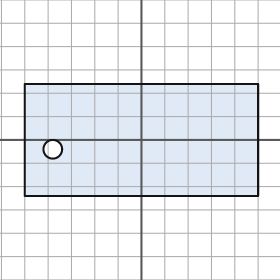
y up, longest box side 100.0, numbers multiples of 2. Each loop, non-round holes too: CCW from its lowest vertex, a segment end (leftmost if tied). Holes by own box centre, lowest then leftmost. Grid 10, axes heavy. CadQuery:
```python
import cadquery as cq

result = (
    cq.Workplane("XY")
    .moveTo(-50.0, -24.0)
    .lineTo(50.0, -24.0)
    .lineTo(50.0, 24.0)
    .lineTo(-50.0, 24.0)
    .close()
    .moveTo(-38.0, -4.0)
    .circle(4.0)
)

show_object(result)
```